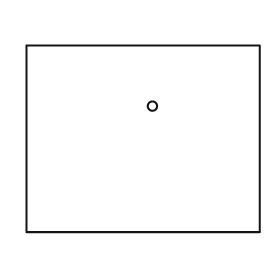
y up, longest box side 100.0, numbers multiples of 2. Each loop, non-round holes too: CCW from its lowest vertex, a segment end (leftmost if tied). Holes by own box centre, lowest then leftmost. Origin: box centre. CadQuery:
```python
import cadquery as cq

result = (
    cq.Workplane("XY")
    .moveTo(-50.0, -40.0)
    .lineTo(50.0, -40.0)
    .lineTo(50.0, 40.0)
    .lineTo(-50.0, 40.0)
    .close()
    .moveTo(4.0, 14.0)
    .circle(2.0)
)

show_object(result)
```